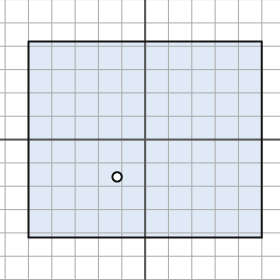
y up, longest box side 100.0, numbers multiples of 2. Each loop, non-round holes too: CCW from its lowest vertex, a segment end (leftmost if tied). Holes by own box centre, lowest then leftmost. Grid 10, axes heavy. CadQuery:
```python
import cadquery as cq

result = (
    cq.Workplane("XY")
    .moveTo(-50.0, -42.0)
    .lineTo(50.0, -42.0)
    .lineTo(50.0, 42.0)
    .lineTo(-50.0, 42.0)
    .close()
    .moveTo(-12.0, -16.0)
    .circle(2.0)
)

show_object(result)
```